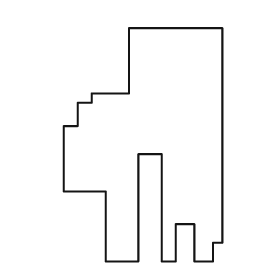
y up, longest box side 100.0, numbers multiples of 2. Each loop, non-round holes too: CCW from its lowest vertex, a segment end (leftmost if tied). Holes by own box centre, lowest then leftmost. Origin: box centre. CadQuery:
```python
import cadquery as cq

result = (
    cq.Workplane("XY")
    .moveTo(-16.0, -50.0)
    .lineTo(-2.0, -50.0)
    .lineTo(-2.0, -4.0)
    .lineTo(8.0, -4.0)
    .lineTo(8.0, -50.0)
    .lineTo(14.0, -50.0)
    .lineTo(14.0, -34.0)
    .lineTo(22.0, -34.0)
    .lineTo(22.0, -50.0)
    .lineTo(30.0, -50.0)
    .lineTo(30.0, -42.0)
    .lineTo(34.0, -42.0)
    .lineTo(34.0, 50.0)
    .lineTo(-6.0, 50.0)
    .lineTo(-6.0, 22.0)
    .lineTo(-22.0, 22.0)
    .lineTo(-22.0, 18.0)
    .lineTo(-28.0, 18.0)
    .lineTo(-28.0, 8.0)
    .lineTo(-34.0, 8.0)
    .lineTo(-34.0, -20.0)
    .lineTo(-16.0, -20.0)
    .close()
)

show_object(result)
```